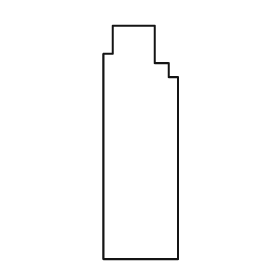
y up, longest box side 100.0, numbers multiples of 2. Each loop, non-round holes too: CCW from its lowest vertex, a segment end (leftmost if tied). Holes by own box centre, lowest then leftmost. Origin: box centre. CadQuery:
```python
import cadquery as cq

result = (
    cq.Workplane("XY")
    .moveTo(-16.0, -50.0)
    .lineTo(16.0, -50.0)
    .lineTo(16.0, 28.0)
    .lineTo(12.0, 28.0)
    .lineTo(12.0, 34.0)
    .lineTo(6.0, 34.0)
    .lineTo(6.0, 50.0)
    .lineTo(-12.0, 50.0)
    .lineTo(-12.0, 38.0)
    .lineTo(-16.0, 38.0)
    .close()
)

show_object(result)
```